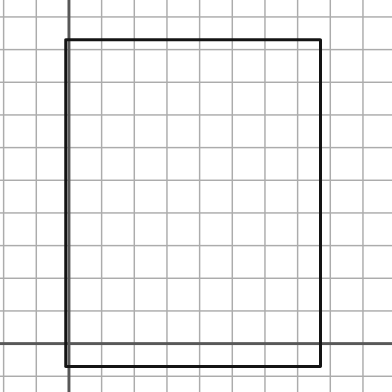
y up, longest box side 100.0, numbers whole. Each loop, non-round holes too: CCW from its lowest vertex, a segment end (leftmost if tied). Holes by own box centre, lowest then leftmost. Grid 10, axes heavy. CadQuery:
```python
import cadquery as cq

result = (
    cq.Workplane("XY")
    .moveTo(-1.0, -7.0)
    .lineTo(77.0, -7.0)
    .lineTo(77.0, 93.0)
    .lineTo(-1.0, 93.0)
    .close()
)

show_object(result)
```